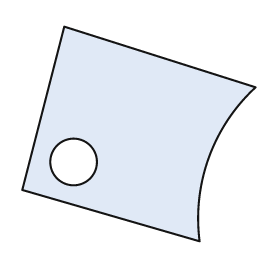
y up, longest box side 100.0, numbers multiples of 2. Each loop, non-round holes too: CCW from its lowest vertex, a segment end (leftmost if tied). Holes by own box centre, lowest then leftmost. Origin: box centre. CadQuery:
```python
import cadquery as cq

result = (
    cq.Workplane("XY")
    .moveTo(26.0, -46.0)
    .threePointArc((30.0, -10.0), (50.0, 20.0))
    .lineTo(-32.0, 46.0)
    .lineTo(-50.0, -24.0)
    .close()
    .moveTo(-28.0, -12.0)
    .circle(10.0)
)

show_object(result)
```